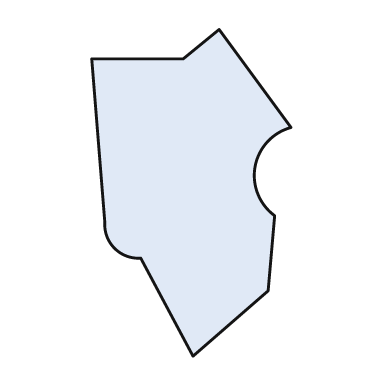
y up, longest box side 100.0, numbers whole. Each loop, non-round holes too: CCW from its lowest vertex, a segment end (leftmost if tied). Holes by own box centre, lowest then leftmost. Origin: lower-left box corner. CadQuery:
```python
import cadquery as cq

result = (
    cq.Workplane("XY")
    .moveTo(31.0, 0.0)
    .lineTo(54.0, 20.0)
    .lineTo(56.0, 43.0)
    .threePointArc((50.0, 58.0), (61.0, 70.0))
    .lineTo(39.0, 100.0)
    .lineTo(28.0, 91.0)
    .lineTo(0.0, 91.0)
    .lineTo(4.0, 41.0)
    .threePointArc((7.0, 33.0), (15.0, 30.0))
    .close()
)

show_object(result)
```